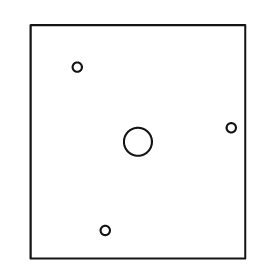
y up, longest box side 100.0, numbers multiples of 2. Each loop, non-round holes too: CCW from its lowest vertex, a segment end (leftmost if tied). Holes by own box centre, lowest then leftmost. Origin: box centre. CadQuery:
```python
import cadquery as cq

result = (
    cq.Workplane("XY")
    .moveTo(-46.0, -50.0)
    .lineTo(46.0, -50.0)
    .lineTo(46.0, 50.0)
    .lineTo(-46.0, 50.0)
    .close()
    .moveTo(-14.0, -38.0)
    .circle(2.0)
    .moveTo(0.0, 0.0)
    .circle(6.0)
    .moveTo(40.0, 6.0)
    .circle(2.0)
    .moveTo(-26.0, 32.0)
    .circle(2.0)
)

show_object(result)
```